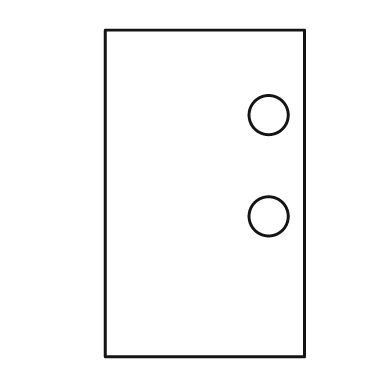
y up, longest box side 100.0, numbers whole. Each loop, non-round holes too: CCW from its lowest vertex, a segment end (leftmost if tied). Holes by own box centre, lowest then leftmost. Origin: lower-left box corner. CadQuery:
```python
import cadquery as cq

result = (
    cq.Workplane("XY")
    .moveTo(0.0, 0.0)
    .lineTo(61.0, 0.0)
    .lineTo(61.0, 100.0)
    .lineTo(0.0, 100.0)
    .close()
    .moveTo(50.0, 43.0)
    .circle(6.0)
    .moveTo(50.0, 74.0)
    .circle(6.0)
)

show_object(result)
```